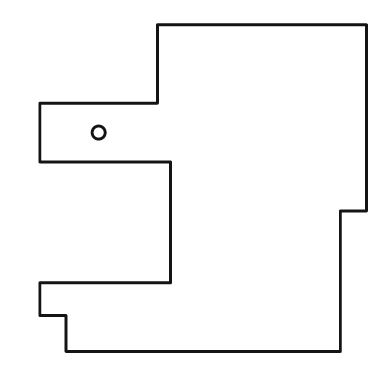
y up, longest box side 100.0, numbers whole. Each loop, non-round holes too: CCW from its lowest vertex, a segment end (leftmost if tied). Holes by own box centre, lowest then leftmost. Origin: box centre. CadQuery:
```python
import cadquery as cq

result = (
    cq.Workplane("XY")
    .moveTo(-42.0, -50.0)
    .lineTo(42.0, -50.0)
    .lineTo(42.0, -7.0)
    .lineTo(50.0, -7.0)
    .lineTo(50.0, 50.0)
    .lineTo(-14.0, 50.0)
    .lineTo(-14.0, 26.0)
    .lineTo(-50.0, 26.0)
    .lineTo(-50.0, 8.0)
    .lineTo(-10.0, 8.0)
    .lineTo(-10.0, -29.0)
    .lineTo(-50.0, -29.0)
    .lineTo(-50.0, -39.0)
    .lineTo(-42.0, -39.0)
    .close()
    .moveTo(-32.0, 17.0)
    .circle(2.0)
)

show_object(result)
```